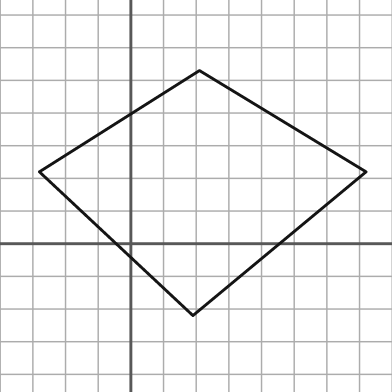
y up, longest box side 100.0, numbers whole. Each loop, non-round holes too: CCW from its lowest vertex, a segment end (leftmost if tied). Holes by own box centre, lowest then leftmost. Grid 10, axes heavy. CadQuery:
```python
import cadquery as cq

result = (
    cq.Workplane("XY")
    .moveTo(19.0, -22.0)
    .lineTo(72.0, 22.0)
    .lineTo(21.0, 53.0)
    .lineTo(-28.0, 22.0)
    .close()
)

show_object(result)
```